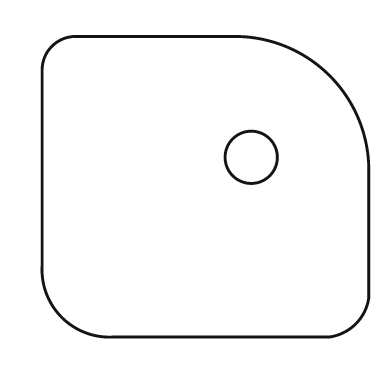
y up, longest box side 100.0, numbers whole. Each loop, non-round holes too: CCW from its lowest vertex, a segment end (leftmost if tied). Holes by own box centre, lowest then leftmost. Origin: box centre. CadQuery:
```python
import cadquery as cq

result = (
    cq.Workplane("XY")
    .moveTo(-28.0, -46.0)
    .lineTo(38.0, -46.0)
    .threePointArc((46.0, -42.0), (50.0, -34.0))
    .lineTo(50.0, 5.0)
    .threePointArc((38.0, 34.0), (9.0, 46.0))
    .lineTo(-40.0, 46.0)
    .threePointArc((-47.0, 43.0), (-50.0, 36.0))
    .lineTo(-50.0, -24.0)
    .threePointArc((-44.0, -40.0), (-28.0, -46.0))
    .close()
    .moveTo(14.0, 9.0)
    .circle(8.0)
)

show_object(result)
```